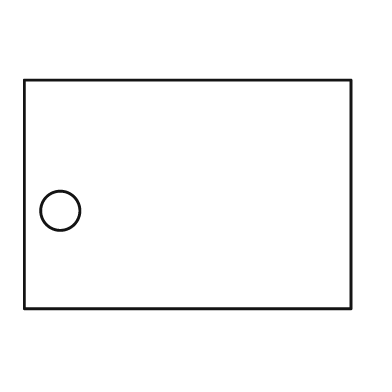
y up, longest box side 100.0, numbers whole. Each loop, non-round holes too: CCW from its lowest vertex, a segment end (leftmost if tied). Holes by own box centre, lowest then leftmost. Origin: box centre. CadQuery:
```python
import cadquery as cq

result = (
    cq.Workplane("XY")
    .moveTo(-50.0, -35.0)
    .lineTo(50.0, -35.0)
    .lineTo(50.0, 35.0)
    .lineTo(-50.0, 35.0)
    .close()
    .moveTo(-39.0, -5.0)
    .circle(6.0)
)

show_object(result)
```